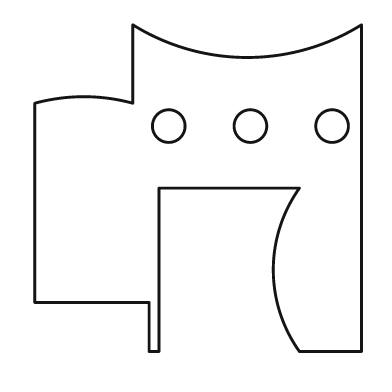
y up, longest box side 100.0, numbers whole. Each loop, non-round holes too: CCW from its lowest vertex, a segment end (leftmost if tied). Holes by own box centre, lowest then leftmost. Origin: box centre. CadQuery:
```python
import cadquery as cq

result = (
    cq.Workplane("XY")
    .moveTo(-15.0, -50.0)
    .lineTo(-12.0, -50.0)
    .lineTo(-12.0, 0.0)
    .lineTo(31.0, 0.0)
    .threePointArc((23.0, -25.0), (31.0, -50.0))
    .lineTo(50.0, -50.0)
    .lineTo(50.0, 50.0)
    .threePointArc((15.0, 40.0), (-20.0, 50.0))
    .lineTo(-20.0, 26.0)
    .threePointArc((-35.0, 28.0), (-50.0, 26.0))
    .lineTo(-50.0, -35.0)
    .lineTo(-15.0, -35.0)
    .close()
    .moveTo(-9.0, 19.0)
    .circle(5.0)
    .moveTo(16.0, 19.0)
    .circle(5.0)
    .moveTo(41.0, 19.0)
    .circle(5.0)
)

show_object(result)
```